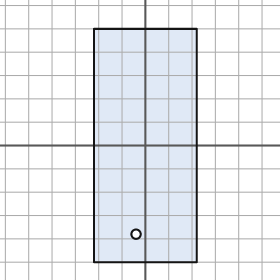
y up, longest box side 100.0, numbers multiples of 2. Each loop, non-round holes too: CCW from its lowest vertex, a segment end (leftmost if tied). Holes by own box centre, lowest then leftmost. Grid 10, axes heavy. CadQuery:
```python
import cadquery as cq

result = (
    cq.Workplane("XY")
    .moveTo(-22.0, -50.0)
    .lineTo(22.0, -50.0)
    .lineTo(22.0, 50.0)
    .lineTo(-22.0, 50.0)
    .close()
    .moveTo(-4.0, -38.0)
    .circle(2.0)
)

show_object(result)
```